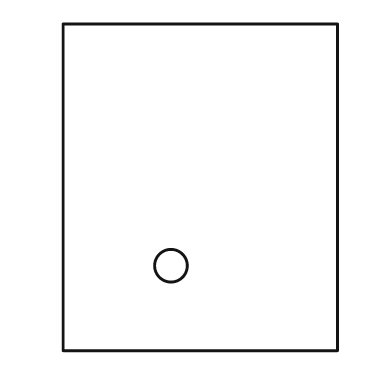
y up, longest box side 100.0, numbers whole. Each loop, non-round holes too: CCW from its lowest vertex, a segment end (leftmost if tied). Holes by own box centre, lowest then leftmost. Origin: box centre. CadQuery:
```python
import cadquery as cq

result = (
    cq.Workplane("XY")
    .moveTo(-42.0, -50.0)
    .lineTo(42.0, -50.0)
    .lineTo(42.0, 50.0)
    .lineTo(-42.0, 50.0)
    .close()
    .moveTo(-9.0, -24.0)
    .circle(5.0)
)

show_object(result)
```